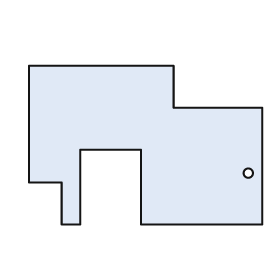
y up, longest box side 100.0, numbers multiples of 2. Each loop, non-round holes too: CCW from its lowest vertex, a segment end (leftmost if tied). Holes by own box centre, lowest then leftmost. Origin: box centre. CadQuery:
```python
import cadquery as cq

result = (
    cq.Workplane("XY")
    .moveTo(-36.0, -34.0)
    .lineTo(-28.0, -34.0)
    .lineTo(-28.0, -2.0)
    .lineTo(-2.0, -2.0)
    .lineTo(-2.0, -34.0)
    .lineTo(50.0, -34.0)
    .lineTo(50.0, 16.0)
    .lineTo(12.0, 16.0)
    .lineTo(12.0, 34.0)
    .lineTo(-50.0, 34.0)
    .lineTo(-50.0, -16.0)
    .lineTo(-36.0, -16.0)
    .close()
    .moveTo(44.0, -12.0)
    .circle(2.0)
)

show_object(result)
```